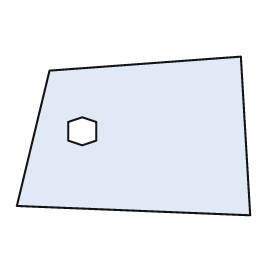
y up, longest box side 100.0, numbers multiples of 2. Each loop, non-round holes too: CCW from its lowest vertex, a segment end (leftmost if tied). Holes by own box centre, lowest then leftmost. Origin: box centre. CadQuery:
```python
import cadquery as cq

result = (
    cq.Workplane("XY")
    .moveTo(50.0, -34.0)
    .lineTo(46.0, 34.0)
    .lineTo(-36.0, 28.0)
    .lineTo(-50.0, -30.0)
    .close()
    .moveTo(-22.0, -4.0)
    .lineTo(-16.0, -2.0)
    .lineTo(-16.0, 6.0)
    .lineTo(-22.0, 8.0)
    .lineTo(-28.0, 6.0)
    .lineTo(-28.0, -2.0)
    .close()
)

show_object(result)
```